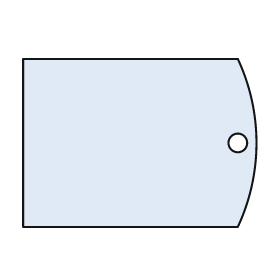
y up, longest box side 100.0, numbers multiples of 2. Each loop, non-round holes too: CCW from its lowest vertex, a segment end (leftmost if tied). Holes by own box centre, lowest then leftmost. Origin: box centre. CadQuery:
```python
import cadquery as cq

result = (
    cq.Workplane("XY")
    .moveTo(-50.0, -36.0)
    .lineTo(42.0, -36.0)
    .threePointArc((50.0, 0.0), (42.0, 36.0))
    .lineTo(-50.0, 36.0)
    .close()
    .moveTo(42.0, 0.0)
    .circle(4.0)
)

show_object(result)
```